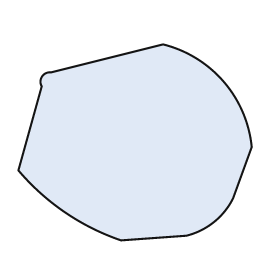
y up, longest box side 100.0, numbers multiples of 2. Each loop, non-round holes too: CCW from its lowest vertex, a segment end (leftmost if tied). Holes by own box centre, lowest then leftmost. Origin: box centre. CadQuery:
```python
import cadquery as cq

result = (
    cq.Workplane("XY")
    .moveTo(-6.0, -42.0)
    .lineTo(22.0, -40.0)
    .threePointArc((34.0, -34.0), (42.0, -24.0))
    .lineTo(50.0, -2.0)
    .threePointArc((38.0, 26.0), (12.0, 42.0))
    .lineTo(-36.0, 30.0)
    .threePointArc((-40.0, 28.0), (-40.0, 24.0))
    .lineTo(-50.0, -12.0)
    .threePointArc((-30.0, -30.0), (-6.0, -42.0))
    .close()
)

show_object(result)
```